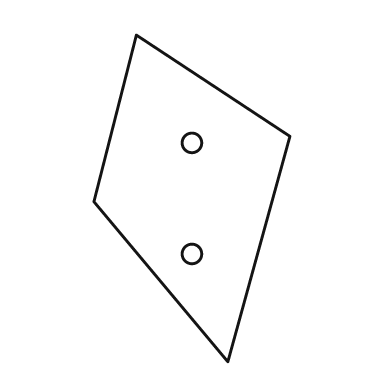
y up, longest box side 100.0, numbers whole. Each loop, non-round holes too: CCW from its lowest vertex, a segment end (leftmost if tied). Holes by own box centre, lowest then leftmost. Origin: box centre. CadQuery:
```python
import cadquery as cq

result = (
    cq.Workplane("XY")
    .moveTo(11.0, -50.0)
    .lineTo(30.0, 19.0)
    .lineTo(-17.0, 50.0)
    .lineTo(-30.0, -1.0)
    .close()
    .moveTo(0.0, -17.0)
    .circle(3.0)
    .moveTo(0.0, 17.0)
    .circle(3.0)
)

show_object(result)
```